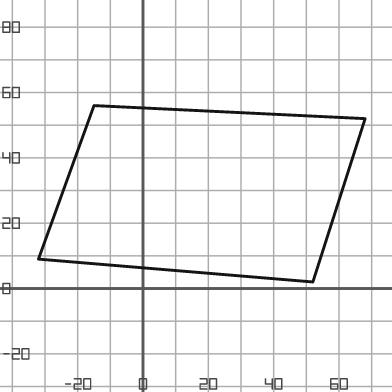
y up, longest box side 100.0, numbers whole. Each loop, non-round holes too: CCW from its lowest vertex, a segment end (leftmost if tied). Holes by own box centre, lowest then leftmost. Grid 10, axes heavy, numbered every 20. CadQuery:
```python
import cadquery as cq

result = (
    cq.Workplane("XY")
    .moveTo(52.0, 2.0)
    .lineTo(68.0, 52.0)
    .lineTo(-15.0, 56.0)
    .lineTo(-32.0, 9.0)
    .close()
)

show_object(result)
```